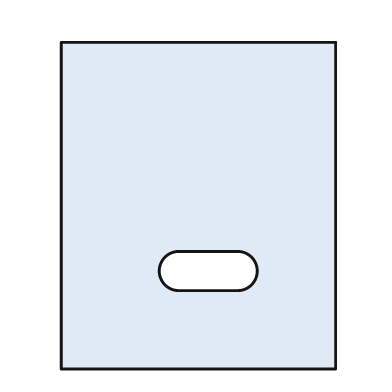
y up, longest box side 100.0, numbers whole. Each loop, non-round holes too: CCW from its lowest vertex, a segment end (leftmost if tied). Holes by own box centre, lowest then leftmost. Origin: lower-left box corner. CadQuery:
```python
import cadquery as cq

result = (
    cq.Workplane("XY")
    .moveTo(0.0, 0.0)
    .lineTo(84.0, 0.0)
    .lineTo(84.0, 100.0)
    .lineTo(0.0, 100.0)
    .close()
    .moveTo(36.0, 24.0)
    .lineTo(54.0, 24.0)
    .threePointArc((60.0, 30.0), (54.0, 36.0))
    .lineTo(36.0, 36.0)
    .threePointArc((30.0, 30.0), (36.0, 24.0))
    .close()
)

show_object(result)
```